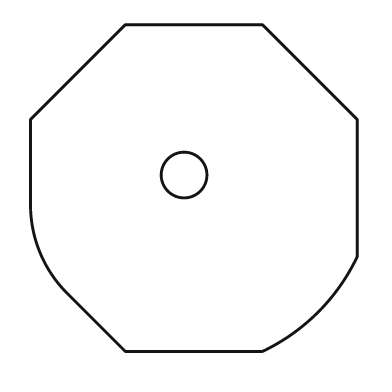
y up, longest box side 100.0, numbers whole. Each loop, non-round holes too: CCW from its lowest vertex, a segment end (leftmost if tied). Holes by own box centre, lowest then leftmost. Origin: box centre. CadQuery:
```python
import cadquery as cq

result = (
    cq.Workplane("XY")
    .moveTo(-21.0, -50.0)
    .lineTo(21.0, -50.0)
    .threePointArc((38.0, -38.0), (50.0, -21.0))
    .lineTo(50.0, 21.0)
    .lineTo(21.0, 50.0)
    .lineTo(-21.0, 50.0)
    .lineTo(-50.0, 21.0)
    .lineTo(-50.0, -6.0)
    .threePointArc((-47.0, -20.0), (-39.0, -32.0))
    .close()
    .moveTo(-3.0, 4.0)
    .circle(7.0)
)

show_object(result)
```